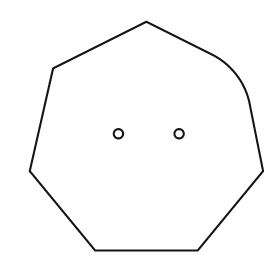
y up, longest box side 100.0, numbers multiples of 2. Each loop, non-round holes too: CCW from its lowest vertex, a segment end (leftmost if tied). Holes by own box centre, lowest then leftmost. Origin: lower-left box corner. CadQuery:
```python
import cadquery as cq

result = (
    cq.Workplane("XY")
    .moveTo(28.0, 0.0)
    .lineTo(72.0, 0.0)
    .lineTo(100.0, 34.0)
    .lineTo(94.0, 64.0)
    .threePointArc((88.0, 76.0), (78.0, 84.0))
    .lineTo(50.0, 98.0)
    .lineTo(10.0, 78.0)
    .lineTo(0.0, 34.0)
    .close()
    .moveTo(38.0, 50.0)
    .circle(2.0)
    .moveTo(64.0, 50.0)
    .circle(2.0)
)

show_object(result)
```